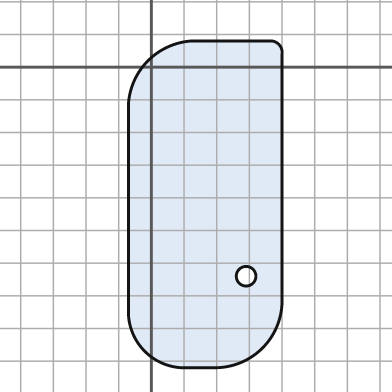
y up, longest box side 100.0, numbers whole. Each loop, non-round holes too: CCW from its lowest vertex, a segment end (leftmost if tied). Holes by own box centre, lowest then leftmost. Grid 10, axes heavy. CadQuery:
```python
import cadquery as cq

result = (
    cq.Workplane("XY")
    .moveTo(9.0, -92.0)
    .lineTo(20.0, -92.0)
    .threePointArc((34.0, -86.0), (40.0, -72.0))
    .lineTo(40.0, 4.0)
    .threePointArc((39.0, 7.0), (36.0, 8.0))
    .lineTo(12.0, 8.0)
    .threePointArc((-1.0, 2.0), (-7.0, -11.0))
    .lineTo(-7.0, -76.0)
    .threePointArc((-2.0, -87.0), (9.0, -92.0))
    .close()
    .moveTo(29.0, -64.0)
    .circle(3.0)
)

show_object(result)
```